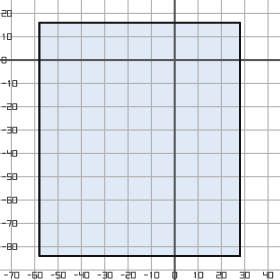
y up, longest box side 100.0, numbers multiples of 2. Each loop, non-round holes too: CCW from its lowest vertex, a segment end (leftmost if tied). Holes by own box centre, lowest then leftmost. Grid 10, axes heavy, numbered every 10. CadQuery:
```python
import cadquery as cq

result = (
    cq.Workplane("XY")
    .moveTo(-58.0, -84.0)
    .lineTo(28.0, -84.0)
    .lineTo(28.0, 16.0)
    .lineTo(-58.0, 16.0)
    .close()
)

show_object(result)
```